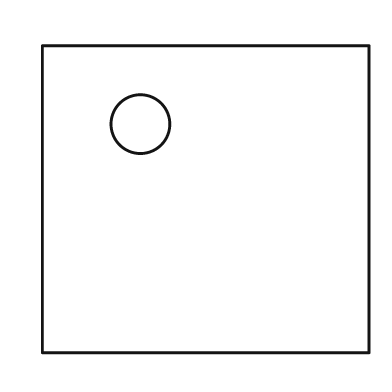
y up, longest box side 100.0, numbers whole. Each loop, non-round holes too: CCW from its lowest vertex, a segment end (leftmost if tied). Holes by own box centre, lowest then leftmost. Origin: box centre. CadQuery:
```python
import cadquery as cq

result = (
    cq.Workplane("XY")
    .moveTo(-50.0, -47.0)
    .lineTo(50.0, -47.0)
    .lineTo(50.0, 47.0)
    .lineTo(-50.0, 47.0)
    .close()
    .moveTo(-20.0, 23.0)
    .circle(9.0)
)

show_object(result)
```